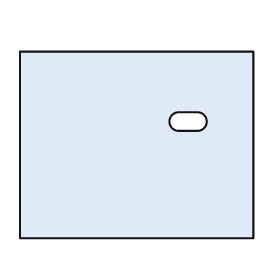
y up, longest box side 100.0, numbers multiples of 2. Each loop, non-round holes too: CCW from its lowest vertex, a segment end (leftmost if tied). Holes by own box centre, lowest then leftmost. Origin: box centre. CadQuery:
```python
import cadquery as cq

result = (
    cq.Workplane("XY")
    .moveTo(-50.0, -40.0)
    .lineTo(50.0, -40.0)
    .lineTo(50.0, 40.0)
    .lineTo(-50.0, 40.0)
    .close()
    .moveTo(18.0, 6.0)
    .lineTo(26.0, 6.0)
    .threePointArc((30.0, 10.0), (26.0, 14.0))
    .lineTo(18.0, 14.0)
    .threePointArc((14.0, 10.0), (18.0, 6.0))
    .close()
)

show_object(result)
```